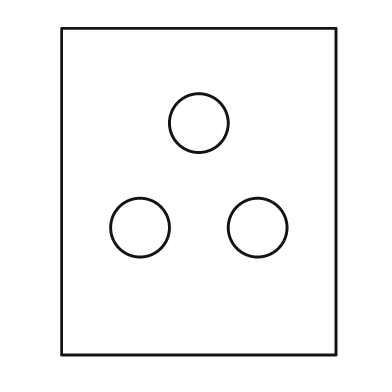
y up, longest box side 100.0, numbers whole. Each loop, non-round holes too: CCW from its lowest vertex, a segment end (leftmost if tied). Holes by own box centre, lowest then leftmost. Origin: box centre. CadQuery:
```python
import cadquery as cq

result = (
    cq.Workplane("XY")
    .moveTo(-42.0, -50.0)
    .lineTo(42.0, -50.0)
    .lineTo(42.0, 50.0)
    .lineTo(-42.0, 50.0)
    .close()
    .moveTo(-18.0, -11.0)
    .circle(9.0)
    .moveTo(18.0, -11.0)
    .circle(9.0)
    .moveTo(0.0, 21.0)
    .circle(9.0)
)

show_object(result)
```